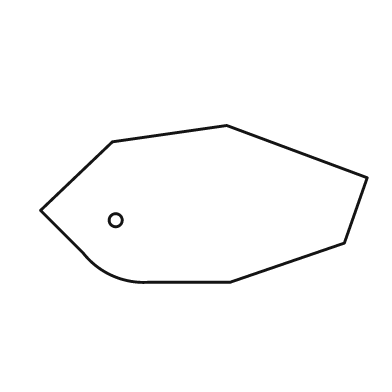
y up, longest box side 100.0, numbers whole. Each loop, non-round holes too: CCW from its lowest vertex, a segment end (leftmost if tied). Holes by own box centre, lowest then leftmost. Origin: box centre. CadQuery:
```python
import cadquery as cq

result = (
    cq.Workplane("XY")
    .moveTo(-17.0, -24.0)
    .lineTo(8.0, -24.0)
    .lineTo(43.0, -12.0)
    .lineTo(50.0, 8.0)
    .lineTo(7.0, 24.0)
    .lineTo(-28.0, 19.0)
    .lineTo(-50.0, -2.0)
    .lineTo(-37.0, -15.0)
    .threePointArc((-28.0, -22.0), (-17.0, -24.0))
    .close()
    .moveTo(-27.0, -5.0)
    .circle(2.0)
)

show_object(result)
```